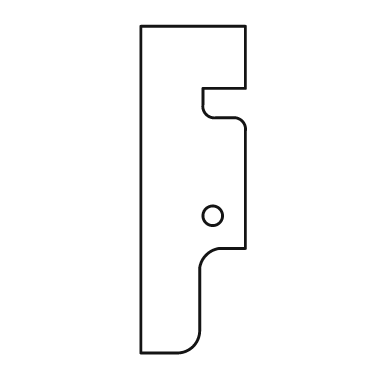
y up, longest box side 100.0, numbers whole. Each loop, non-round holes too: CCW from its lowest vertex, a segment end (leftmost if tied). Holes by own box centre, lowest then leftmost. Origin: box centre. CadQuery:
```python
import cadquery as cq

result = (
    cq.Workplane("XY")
    .moveTo(-16.0, -50.0)
    .lineTo(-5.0, -50.0)
    .threePointArc((0.0, -48.0), (2.0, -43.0))
    .lineTo(2.0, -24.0)
    .threePointArc((4.0, -20.0), (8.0, -18.0))
    .lineTo(16.0, -18.0)
    .lineTo(16.0, 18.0)
    .threePointArc((15.0, 21.0), (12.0, 22.0))
    .lineTo(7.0, 22.0)
    .threePointArc((4.0, 23.0), (3.0, 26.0))
    .lineTo(3.0, 31.0)
    .lineTo(16.0, 31.0)
    .lineTo(16.0, 50.0)
    .lineTo(-16.0, 50.0)
    .close()
    .moveTo(6.0, -8.0)
    .circle(3.0)
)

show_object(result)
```